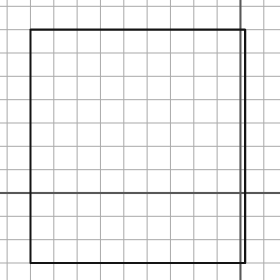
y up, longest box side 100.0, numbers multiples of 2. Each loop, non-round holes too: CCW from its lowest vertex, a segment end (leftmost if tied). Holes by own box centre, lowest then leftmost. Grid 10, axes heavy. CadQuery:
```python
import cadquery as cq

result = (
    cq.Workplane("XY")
    .moveTo(-90.0, -30.0)
    .lineTo(2.0, -30.0)
    .lineTo(2.0, 70.0)
    .lineTo(-90.0, 70.0)
    .close()
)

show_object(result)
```